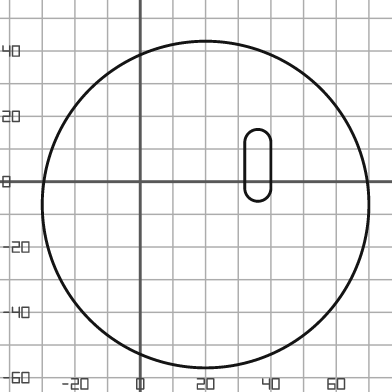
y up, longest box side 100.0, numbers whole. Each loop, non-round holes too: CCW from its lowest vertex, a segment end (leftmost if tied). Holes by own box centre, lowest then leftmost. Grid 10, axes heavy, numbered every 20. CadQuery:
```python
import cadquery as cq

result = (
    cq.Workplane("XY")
    .moveTo(20.0, -7.0)
    .circle(50.0)
    .moveTo(32.0, -2.0)
    .threePointArc((36.0, -6.0), (40.0, -2.0))
    .lineTo(40.0, 12.0)
    .threePointArc((36.0, 16.0), (32.0, 12.0))
    .close()
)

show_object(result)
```